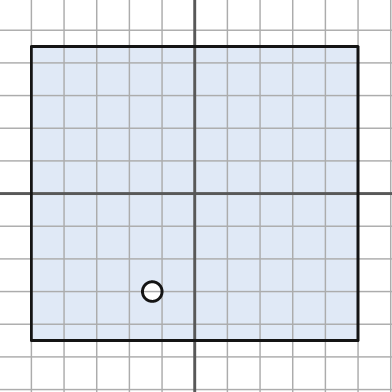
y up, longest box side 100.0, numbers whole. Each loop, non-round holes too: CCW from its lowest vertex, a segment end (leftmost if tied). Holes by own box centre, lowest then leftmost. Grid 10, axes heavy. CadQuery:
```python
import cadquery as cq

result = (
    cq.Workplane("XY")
    .moveTo(-50.0, -45.0)
    .lineTo(50.0, -45.0)
    .lineTo(50.0, 45.0)
    .lineTo(-50.0, 45.0)
    .close()
    .moveTo(-13.0, -30.0)
    .circle(3.0)
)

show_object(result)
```